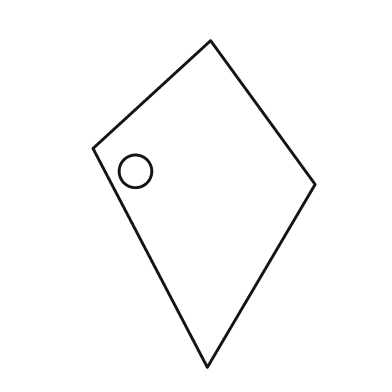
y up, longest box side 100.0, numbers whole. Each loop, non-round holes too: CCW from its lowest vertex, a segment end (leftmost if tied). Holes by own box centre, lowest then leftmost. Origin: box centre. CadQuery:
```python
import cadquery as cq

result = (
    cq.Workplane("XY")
    .moveTo(1.0, -50.0)
    .lineTo(34.0, 6.0)
    .lineTo(2.0, 50.0)
    .lineTo(-34.0, 17.0)
    .close()
    .moveTo(-21.0, 10.0)
    .circle(5.0)
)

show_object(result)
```